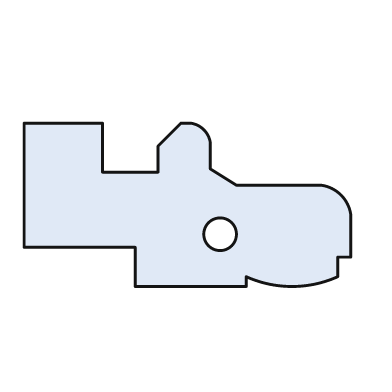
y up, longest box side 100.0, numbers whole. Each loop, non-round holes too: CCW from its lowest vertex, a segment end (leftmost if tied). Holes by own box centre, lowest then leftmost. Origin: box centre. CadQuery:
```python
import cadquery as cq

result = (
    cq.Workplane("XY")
    .moveTo(-16.0, -25.0)
    .lineTo(18.0, -25.0)
    .lineTo(18.0, -22.0)
    .threePointArc((32.0, -25.0), (46.0, -22.0))
    .lineTo(46.0, -16.0)
    .lineTo(50.0, -16.0)
    .lineTo(50.0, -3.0)
    .threePointArc((47.0, 3.0), (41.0, 6.0))
    .lineTo(15.0, 6.0)
    .lineTo(7.0, 11.0)
    .lineTo(7.0, 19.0)
    .threePointArc((5.0, 23.0), (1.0, 25.0))
    .lineTo(-2.0, 25.0)
    .lineTo(-9.0, 18.0)
    .lineTo(-9.0, 10.0)
    .lineTo(-26.0, 10.0)
    .lineTo(-26.0, 25.0)
    .lineTo(-50.0, 25.0)
    .lineTo(-50.0, -13.0)
    .lineTo(-16.0, -13.0)
    .close()
    .moveTo(10.0, -9.0)
    .circle(5.0)
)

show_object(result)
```